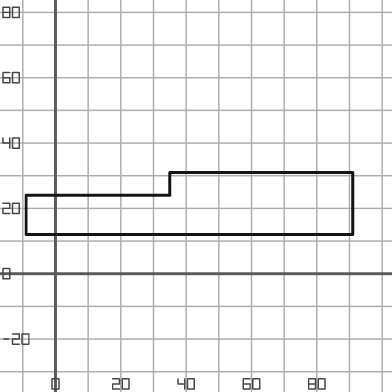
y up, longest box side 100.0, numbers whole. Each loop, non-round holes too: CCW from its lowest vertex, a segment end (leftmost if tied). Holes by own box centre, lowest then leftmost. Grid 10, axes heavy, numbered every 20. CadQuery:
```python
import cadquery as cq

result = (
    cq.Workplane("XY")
    .moveTo(-9.0, 12.0)
    .lineTo(91.0, 12.0)
    .lineTo(91.0, 31.0)
    .lineTo(35.0, 31.0)
    .lineTo(35.0, 24.0)
    .lineTo(-9.0, 24.0)
    .close()
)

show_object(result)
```